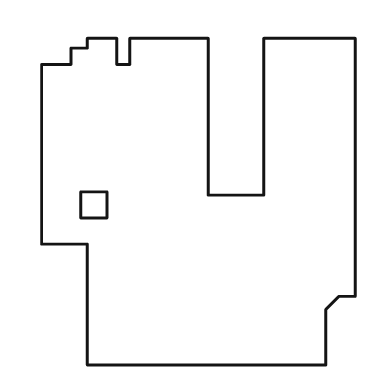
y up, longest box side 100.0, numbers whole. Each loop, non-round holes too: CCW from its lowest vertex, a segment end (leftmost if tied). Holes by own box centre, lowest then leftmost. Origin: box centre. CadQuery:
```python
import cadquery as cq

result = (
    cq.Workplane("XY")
    .moveTo(-34.0, -50.0)
    .lineTo(39.0, -50.0)
    .lineTo(39.0, -33.0)
    .lineTo(43.0, -29.0)
    .lineTo(48.0, -29.0)
    .lineTo(48.0, 50.0)
    .lineTo(20.0, 50.0)
    .lineTo(20.0, 2.0)
    .lineTo(3.0, 2.0)
    .lineTo(3.0, 50.0)
    .lineTo(-21.0, 50.0)
    .lineTo(-21.0, 42.0)
    .lineTo(-25.0, 42.0)
    .lineTo(-25.0, 50.0)
    .lineTo(-34.0, 50.0)
    .lineTo(-34.0, 47.0)
    .lineTo(-39.0, 47.0)
    .lineTo(-39.0, 42.0)
    .lineTo(-48.0, 42.0)
    .lineTo(-48.0, -13.0)
    .lineTo(-34.0, -13.0)
    .close()
    .moveTo(-36.0, -5.0)
    .lineTo(-28.0, -5.0)
    .lineTo(-28.0, 3.0)
    .lineTo(-36.0, 3.0)
    .close()
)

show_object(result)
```